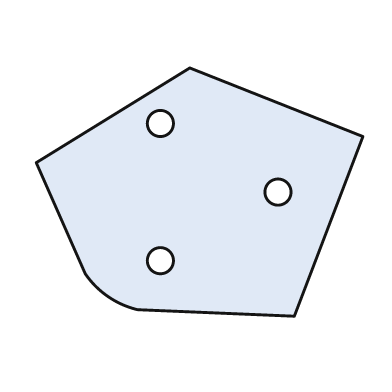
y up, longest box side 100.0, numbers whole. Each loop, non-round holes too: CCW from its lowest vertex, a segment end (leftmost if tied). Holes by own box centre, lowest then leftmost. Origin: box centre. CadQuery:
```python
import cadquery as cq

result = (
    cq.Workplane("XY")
    .moveTo(29.0, -38.0)
    .lineTo(50.0, 17.0)
    .lineTo(-3.0, 38.0)
    .lineTo(-50.0, 9.0)
    .lineTo(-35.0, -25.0)
    .threePointArc((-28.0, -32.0), (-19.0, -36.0))
    .close()
    .moveTo(-12.0, -21.0)
    .circle(4.0)
    .moveTo(24.0, 0.0)
    .circle(4.0)
    .moveTo(-12.0, 21.0)
    .circle(4.0)
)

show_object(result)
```